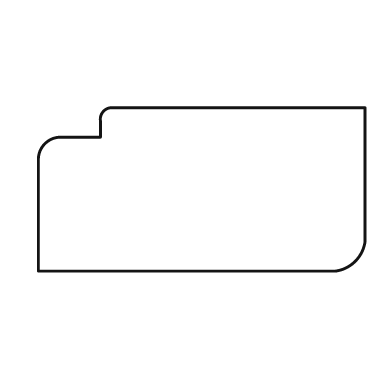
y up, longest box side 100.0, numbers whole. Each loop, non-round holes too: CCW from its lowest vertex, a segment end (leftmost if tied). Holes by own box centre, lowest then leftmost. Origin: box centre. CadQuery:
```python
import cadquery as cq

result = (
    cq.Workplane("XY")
    .moveTo(-50.0, -25.0)
    .lineTo(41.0, -25.0)
    .threePointArc((47.0, -22.0), (50.0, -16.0))
    .lineTo(50.0, 25.0)
    .lineTo(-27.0, 25.0)
    .threePointArc((-30.0, 24.0), (-31.0, 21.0))
    .lineTo(-31.0, 16.0)
    .lineTo(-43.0, 16.0)
    .threePointArc((-48.0, 14.0), (-50.0, 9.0))
    .close()
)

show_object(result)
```